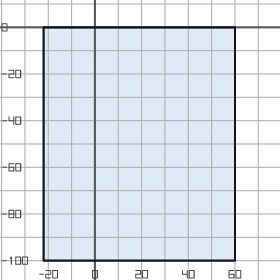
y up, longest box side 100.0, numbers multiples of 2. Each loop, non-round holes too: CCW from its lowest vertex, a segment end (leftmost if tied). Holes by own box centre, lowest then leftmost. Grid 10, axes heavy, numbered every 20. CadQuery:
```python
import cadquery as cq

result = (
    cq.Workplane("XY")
    .moveTo(-22.0, -100.0)
    .lineTo(60.0, -100.0)
    .lineTo(60.0, 0.0)
    .lineTo(-22.0, 0.0)
    .close()
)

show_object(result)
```